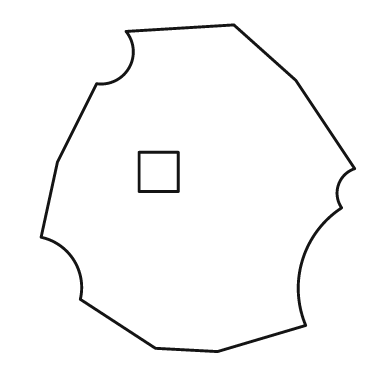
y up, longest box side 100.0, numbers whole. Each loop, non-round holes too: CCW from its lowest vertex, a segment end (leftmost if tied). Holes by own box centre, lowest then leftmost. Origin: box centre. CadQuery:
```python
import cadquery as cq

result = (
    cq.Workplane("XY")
    .moveTo(6.0, -50.0)
    .lineTo(33.0, -42.0)
    .threePointArc((32.0, -22.0), (44.0, -6.0))
    .threePointArc((43.0, 1.0), (48.0, 6.0))
    .lineTo(30.0, 33.0)
    .lineTo(11.0, 50.0)
    .lineTo(-22.0, 48.0)
    .threePointArc((-21.0, 37.0), (-31.0, 32.0))
    .lineTo(-43.0, 8.0)
    .lineTo(-48.0, -15.0)
    .threePointArc((-38.0, -22.0), (-36.0, -34.0))
    .lineTo(-13.0, -49.0)
    .close()
    .moveTo(-18.0, -1.0)
    .lineTo(-6.0, -1.0)
    .lineTo(-6.0, 11.0)
    .lineTo(-18.0, 11.0)
    .close()
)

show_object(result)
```